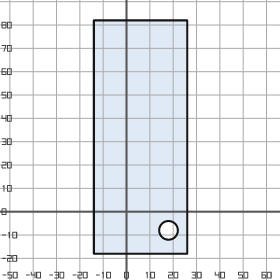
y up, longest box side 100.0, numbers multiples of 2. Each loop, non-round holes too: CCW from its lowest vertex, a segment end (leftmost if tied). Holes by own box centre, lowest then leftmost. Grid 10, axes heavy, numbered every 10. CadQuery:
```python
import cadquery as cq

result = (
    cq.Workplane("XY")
    .moveTo(-14.0, -18.0)
    .lineTo(26.0, -18.0)
    .lineTo(26.0, 82.0)
    .lineTo(-14.0, 82.0)
    .close()
    .moveTo(18.0, -8.0)
    .circle(4.0)
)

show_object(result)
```